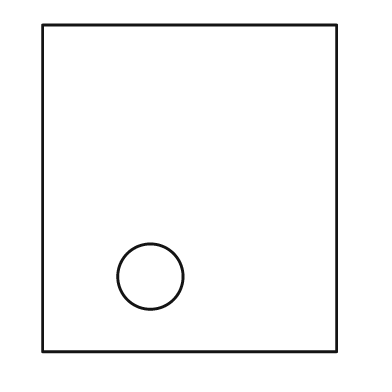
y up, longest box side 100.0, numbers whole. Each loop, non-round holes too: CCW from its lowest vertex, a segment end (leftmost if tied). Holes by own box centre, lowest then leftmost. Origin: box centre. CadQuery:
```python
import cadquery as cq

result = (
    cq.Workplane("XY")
    .moveTo(-45.0, -50.0)
    .lineTo(45.0, -50.0)
    .lineTo(45.0, 50.0)
    .lineTo(-45.0, 50.0)
    .close()
    .moveTo(-12.0, -27.0)
    .circle(10.0)
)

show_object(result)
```